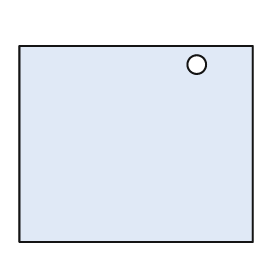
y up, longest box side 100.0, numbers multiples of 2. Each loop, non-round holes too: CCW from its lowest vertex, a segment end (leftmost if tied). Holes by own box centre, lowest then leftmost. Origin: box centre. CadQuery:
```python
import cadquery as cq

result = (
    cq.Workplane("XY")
    .moveTo(-50.0, -42.0)
    .lineTo(50.0, -42.0)
    .lineTo(50.0, 42.0)
    .lineTo(-50.0, 42.0)
    .close()
    .moveTo(26.0, 34.0)
    .circle(4.0)
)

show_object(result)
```